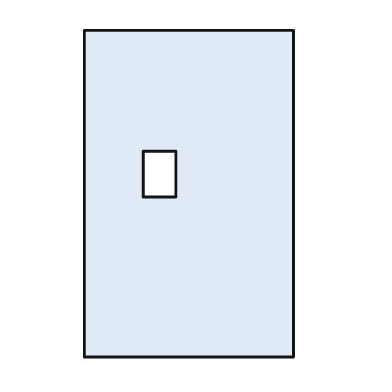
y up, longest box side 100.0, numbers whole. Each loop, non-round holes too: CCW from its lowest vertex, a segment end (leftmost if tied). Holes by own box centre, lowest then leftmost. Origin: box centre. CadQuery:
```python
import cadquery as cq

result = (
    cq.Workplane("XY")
    .moveTo(-32.0, -50.0)
    .lineTo(32.0, -50.0)
    .lineTo(32.0, 50.0)
    .lineTo(-32.0, 50.0)
    .close()
    .moveTo(-14.0, -1.0)
    .lineTo(-4.0, -1.0)
    .lineTo(-4.0, 13.0)
    .lineTo(-14.0, 13.0)
    .close()
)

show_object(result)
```